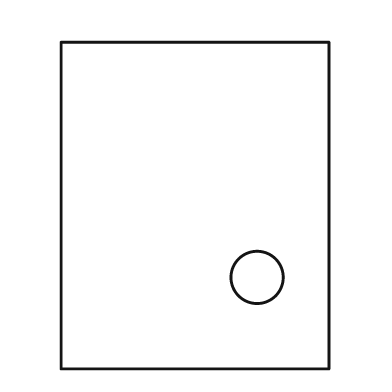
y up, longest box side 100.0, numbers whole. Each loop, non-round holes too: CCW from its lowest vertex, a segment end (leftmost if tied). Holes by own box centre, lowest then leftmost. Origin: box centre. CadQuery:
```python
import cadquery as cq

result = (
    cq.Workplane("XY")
    .moveTo(-41.0, -50.0)
    .lineTo(41.0, -50.0)
    .lineTo(41.0, 50.0)
    .lineTo(-41.0, 50.0)
    .close()
    .moveTo(19.0, -22.0)
    .circle(8.0)
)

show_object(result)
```